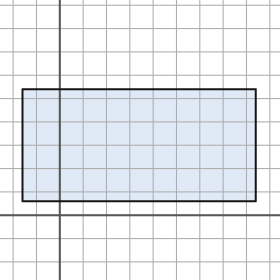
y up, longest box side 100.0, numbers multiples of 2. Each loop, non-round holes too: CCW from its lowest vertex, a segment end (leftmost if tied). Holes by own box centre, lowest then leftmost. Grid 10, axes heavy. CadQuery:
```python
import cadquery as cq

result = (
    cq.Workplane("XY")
    .moveTo(-16.0, 6.0)
    .lineTo(84.0, 6.0)
    .lineTo(84.0, 54.0)
    .lineTo(-16.0, 54.0)
    .close()
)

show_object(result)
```